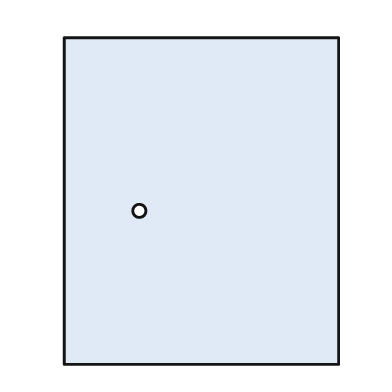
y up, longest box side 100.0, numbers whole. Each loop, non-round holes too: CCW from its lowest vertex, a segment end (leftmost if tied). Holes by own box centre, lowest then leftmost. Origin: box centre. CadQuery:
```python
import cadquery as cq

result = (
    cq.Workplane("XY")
    .moveTo(-42.0, -50.0)
    .lineTo(42.0, -50.0)
    .lineTo(42.0, 50.0)
    .lineTo(-42.0, 50.0)
    .close()
    .moveTo(-19.0, -3.0)
    .circle(2.0)
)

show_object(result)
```